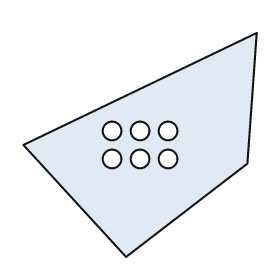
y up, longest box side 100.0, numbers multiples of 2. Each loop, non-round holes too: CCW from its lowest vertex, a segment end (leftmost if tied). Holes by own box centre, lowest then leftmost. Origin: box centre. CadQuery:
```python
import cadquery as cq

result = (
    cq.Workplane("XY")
    .moveTo(-6.0, -48.0)
    .lineTo(46.0, -8.0)
    .lineTo(50.0, 48.0)
    .lineTo(-50.0, 0.0)
    .close()
    .moveTo(-12.0, -6.0)
    .circle(4.0)
    .moveTo(0.0, -6.0)
    .circle(4.0)
    .moveTo(12.0, -6.0)
    .circle(4.0)
    .moveTo(-12.0, 6.0)
    .circle(4.0)
    .moveTo(0.0, 6.0)
    .circle(4.0)
    .moveTo(12.0, 6.0)
    .circle(4.0)
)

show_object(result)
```